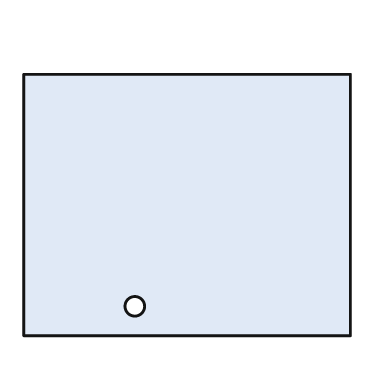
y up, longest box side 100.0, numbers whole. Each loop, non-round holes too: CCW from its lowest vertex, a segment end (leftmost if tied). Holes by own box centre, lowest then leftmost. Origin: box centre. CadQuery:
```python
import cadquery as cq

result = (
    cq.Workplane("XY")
    .moveTo(-50.0, -40.0)
    .lineTo(50.0, -40.0)
    .lineTo(50.0, 40.0)
    .lineTo(-50.0, 40.0)
    .close()
    .moveTo(-16.0, -31.0)
    .circle(3.0)
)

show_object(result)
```